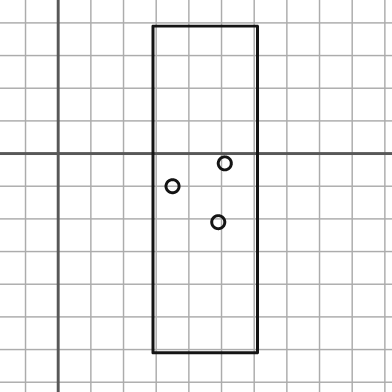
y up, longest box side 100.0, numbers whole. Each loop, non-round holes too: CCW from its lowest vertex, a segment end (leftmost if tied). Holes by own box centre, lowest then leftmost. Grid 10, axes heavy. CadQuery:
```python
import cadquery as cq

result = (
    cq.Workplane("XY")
    .moveTo(29.0, -61.0)
    .lineTo(61.0, -61.0)
    .lineTo(61.0, 39.0)
    .lineTo(29.0, 39.0)
    .close()
    .moveTo(49.0, -21.0)
    .circle(2.0)
    .moveTo(35.0, -10.0)
    .circle(2.0)
    .moveTo(51.0, -3.0)
    .circle(2.0)
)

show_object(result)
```